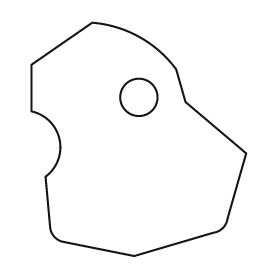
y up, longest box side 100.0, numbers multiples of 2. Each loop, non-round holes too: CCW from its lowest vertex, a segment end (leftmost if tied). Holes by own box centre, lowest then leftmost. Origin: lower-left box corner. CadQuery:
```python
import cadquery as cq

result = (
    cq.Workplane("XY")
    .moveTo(44.0, 0.0)
    .lineTo(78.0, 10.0)
    .threePointArc((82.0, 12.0), (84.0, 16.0))
    .lineTo(92.0, 44.0)
    .lineTo(66.0, 66.0)
    .lineTo(62.0, 80.0)
    .threePointArc((46.0, 94.0), (26.0, 100.0))
    .lineTo(0.0, 82.0)
    .lineTo(0.0, 62.0)
    .threePointArc((12.0, 50.0), (6.0, 34.0))
    .lineTo(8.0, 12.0)
    .threePointArc((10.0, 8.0), (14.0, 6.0))
    .close()
    .moveTo(46.0, 68.0)
    .circle(8.0)
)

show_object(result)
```